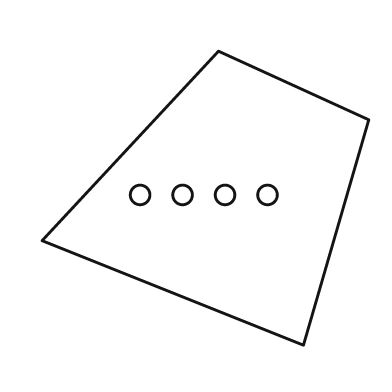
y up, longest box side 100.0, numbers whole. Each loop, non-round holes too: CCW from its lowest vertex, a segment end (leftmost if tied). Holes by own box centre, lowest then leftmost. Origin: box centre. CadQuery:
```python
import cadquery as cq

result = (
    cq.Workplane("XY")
    .moveTo(30.0, -45.0)
    .lineTo(50.0, 24.0)
    .lineTo(4.0, 45.0)
    .lineTo(-50.0, -13.0)
    .close()
    .moveTo(-20.0, 1.0)
    .circle(3.0)
    .moveTo(-7.0, 1.0)
    .circle(3.0)
    .moveTo(6.0, 1.0)
    .circle(3.0)
    .moveTo(19.0, 1.0)
    .circle(3.0)
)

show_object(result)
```